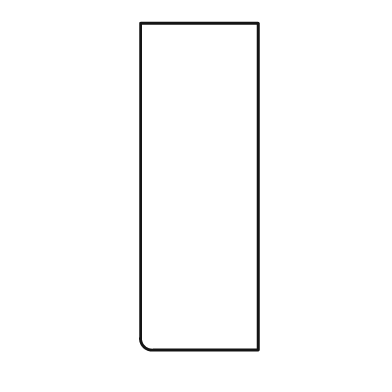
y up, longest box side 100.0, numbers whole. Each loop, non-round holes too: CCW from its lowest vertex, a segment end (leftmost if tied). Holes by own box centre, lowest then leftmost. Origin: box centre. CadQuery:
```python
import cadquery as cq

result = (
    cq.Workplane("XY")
    .moveTo(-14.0, -50.0)
    .lineTo(18.0, -50.0)
    .lineTo(18.0, 50.0)
    .lineTo(-18.0, 50.0)
    .lineTo(-18.0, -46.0)
    .threePointArc((-17.0, -49.0), (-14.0, -50.0))
    .close()
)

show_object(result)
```